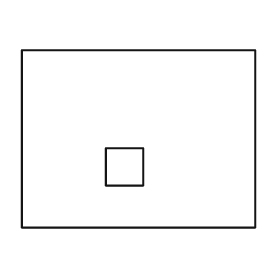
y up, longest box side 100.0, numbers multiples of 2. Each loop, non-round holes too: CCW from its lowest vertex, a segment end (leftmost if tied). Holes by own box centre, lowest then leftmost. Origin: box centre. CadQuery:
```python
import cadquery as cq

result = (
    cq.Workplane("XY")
    .moveTo(-50.0, -38.0)
    .lineTo(50.0, -38.0)
    .lineTo(50.0, 38.0)
    .lineTo(-50.0, 38.0)
    .close()
    .moveTo(-14.0, -20.0)
    .lineTo(2.0, -20.0)
    .lineTo(2.0, -4.0)
    .lineTo(-14.0, -4.0)
    .close()
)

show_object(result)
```